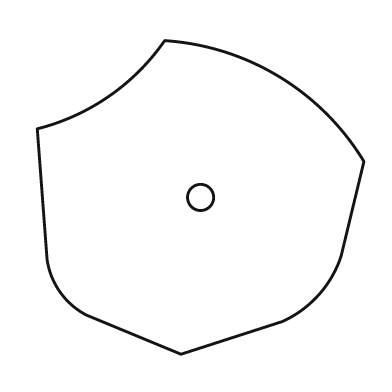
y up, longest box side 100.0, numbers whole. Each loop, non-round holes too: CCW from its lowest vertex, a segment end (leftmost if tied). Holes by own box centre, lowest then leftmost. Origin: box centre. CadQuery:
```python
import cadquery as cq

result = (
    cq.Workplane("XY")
    .moveTo(-6.0, -48.0)
    .lineTo(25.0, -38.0)
    .threePointArc((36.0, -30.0), (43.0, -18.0))
    .lineTo(50.0, 11.0)
    .threePointArc((24.0, 37.0), (-11.0, 48.0))
    .threePointArc((-28.0, 31.0), (-50.0, 21.0))
    .lineTo(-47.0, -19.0)
    .threePointArc((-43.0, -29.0), (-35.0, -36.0))
    .close()
    .moveTo(0.0, 0.0)
    .circle(4.0)
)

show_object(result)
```